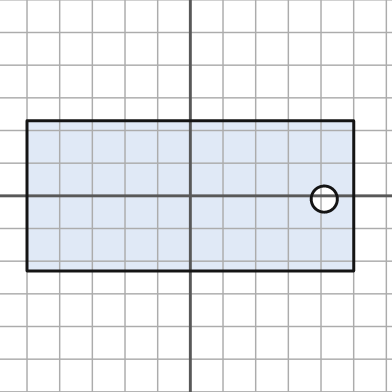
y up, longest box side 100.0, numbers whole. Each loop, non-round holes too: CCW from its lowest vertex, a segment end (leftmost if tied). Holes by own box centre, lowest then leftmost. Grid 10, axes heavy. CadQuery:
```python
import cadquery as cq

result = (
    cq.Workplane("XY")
    .moveTo(-50.0, -23.0)
    .lineTo(50.0, -23.0)
    .lineTo(50.0, 23.0)
    .lineTo(-50.0, 23.0)
    .close()
    .moveTo(41.0, -1.0)
    .circle(4.0)
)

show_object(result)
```